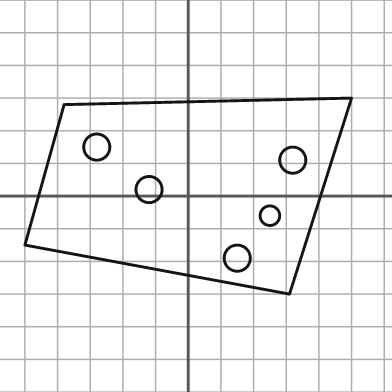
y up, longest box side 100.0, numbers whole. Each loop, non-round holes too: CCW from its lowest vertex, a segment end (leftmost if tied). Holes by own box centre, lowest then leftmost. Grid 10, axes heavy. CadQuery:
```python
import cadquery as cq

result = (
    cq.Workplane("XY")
    .moveTo(31.0, -30.0)
    .lineTo(50.0, 30.0)
    .lineTo(-38.0, 28.0)
    .lineTo(-50.0, -15.0)
    .close()
    .moveTo(15.0, -19.0)
    .circle(4.0)
    .moveTo(25.0, -6.0)
    .circle(3.0)
    .moveTo(-12.0, 2.0)
    .circle(4.0)
    .moveTo(32.0, 11.0)
    .circle(4.0)
    .moveTo(-28.0, 15.0)
    .circle(4.0)
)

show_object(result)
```